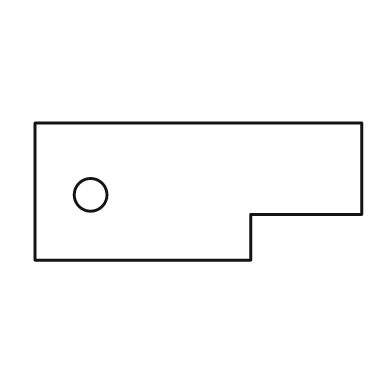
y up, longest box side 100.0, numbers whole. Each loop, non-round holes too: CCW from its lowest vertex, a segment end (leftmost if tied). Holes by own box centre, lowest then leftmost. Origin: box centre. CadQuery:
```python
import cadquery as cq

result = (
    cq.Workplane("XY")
    .moveTo(-50.0, -21.0)
    .lineTo(16.0, -21.0)
    .lineTo(16.0, -7.0)
    .lineTo(50.0, -7.0)
    .lineTo(50.0, 21.0)
    .lineTo(-50.0, 21.0)
    .close()
    .moveTo(-33.0, -1.0)
    .circle(5.0)
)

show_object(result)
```